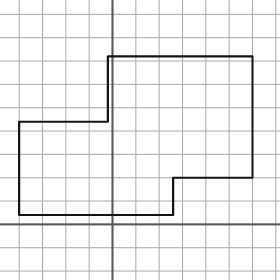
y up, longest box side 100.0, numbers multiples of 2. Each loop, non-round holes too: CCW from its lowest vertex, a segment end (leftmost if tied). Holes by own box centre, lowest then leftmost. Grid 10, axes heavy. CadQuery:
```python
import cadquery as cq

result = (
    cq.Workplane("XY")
    .moveTo(-40.0, 4.0)
    .lineTo(26.0, 4.0)
    .lineTo(26.0, 20.0)
    .lineTo(60.0, 20.0)
    .lineTo(60.0, 72.0)
    .lineTo(-2.0, 72.0)
    .lineTo(-2.0, 44.0)
    .lineTo(-40.0, 44.0)
    .close()
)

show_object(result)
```